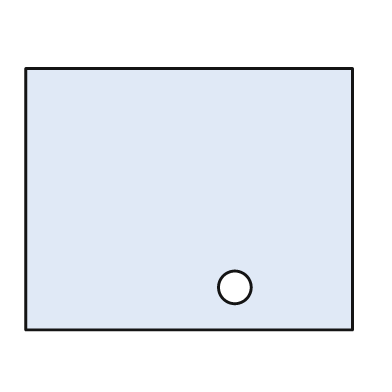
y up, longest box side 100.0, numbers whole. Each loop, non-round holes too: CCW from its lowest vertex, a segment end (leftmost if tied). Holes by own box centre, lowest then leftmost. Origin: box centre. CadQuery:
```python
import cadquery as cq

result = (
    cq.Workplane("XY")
    .moveTo(-50.0, -40.0)
    .lineTo(50.0, -40.0)
    .lineTo(50.0, 40.0)
    .lineTo(-50.0, 40.0)
    .close()
    .moveTo(14.0, -27.0)
    .circle(5.0)
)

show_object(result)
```